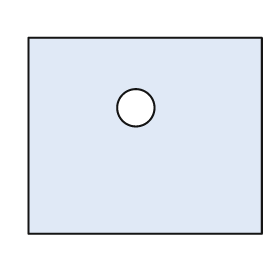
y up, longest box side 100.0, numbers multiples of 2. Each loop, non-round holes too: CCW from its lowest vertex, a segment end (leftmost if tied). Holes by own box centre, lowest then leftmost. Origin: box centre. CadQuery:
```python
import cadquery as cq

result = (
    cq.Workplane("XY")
    .moveTo(-50.0, -42.0)
    .lineTo(50.0, -42.0)
    .lineTo(50.0, 42.0)
    .lineTo(-50.0, 42.0)
    .close()
    .moveTo(-4.0, 12.0)
    .circle(8.0)
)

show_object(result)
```